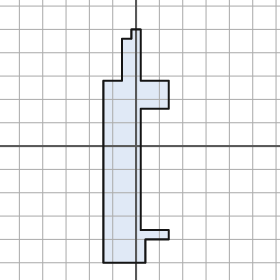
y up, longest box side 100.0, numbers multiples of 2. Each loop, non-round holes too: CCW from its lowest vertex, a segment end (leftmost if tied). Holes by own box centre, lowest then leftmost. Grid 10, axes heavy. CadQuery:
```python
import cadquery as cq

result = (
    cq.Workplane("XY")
    .moveTo(-14.0, -50.0)
    .lineTo(4.0, -50.0)
    .lineTo(4.0, -40.0)
    .lineTo(14.0, -40.0)
    .lineTo(14.0, -36.0)
    .lineTo(2.0, -36.0)
    .lineTo(2.0, 16.0)
    .lineTo(14.0, 16.0)
    .lineTo(14.0, 28.0)
    .lineTo(2.0, 28.0)
    .lineTo(2.0, 50.0)
    .lineTo(-2.0, 50.0)
    .lineTo(-2.0, 46.0)
    .lineTo(-6.0, 46.0)
    .lineTo(-6.0, 28.0)
    .lineTo(-14.0, 28.0)
    .close()
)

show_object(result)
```